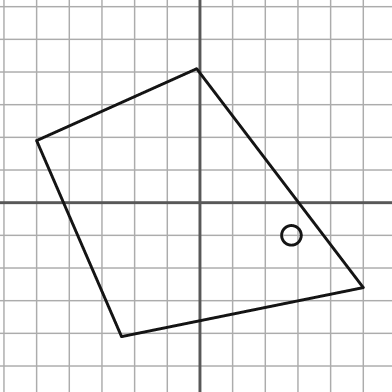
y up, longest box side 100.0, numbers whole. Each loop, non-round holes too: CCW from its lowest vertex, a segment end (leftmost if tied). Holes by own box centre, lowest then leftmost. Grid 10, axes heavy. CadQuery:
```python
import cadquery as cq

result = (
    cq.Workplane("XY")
    .moveTo(-24.0, -41.0)
    .lineTo(50.0, -26.0)
    .lineTo(-1.0, 41.0)
    .lineTo(-50.0, 19.0)
    .close()
    .moveTo(28.0, -10.0)
    .circle(3.0)
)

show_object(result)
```